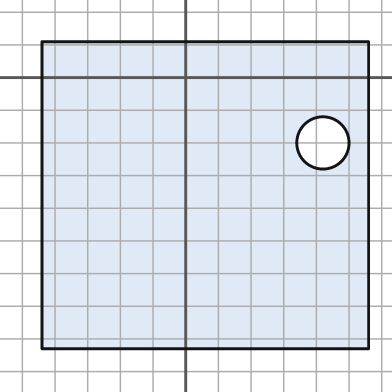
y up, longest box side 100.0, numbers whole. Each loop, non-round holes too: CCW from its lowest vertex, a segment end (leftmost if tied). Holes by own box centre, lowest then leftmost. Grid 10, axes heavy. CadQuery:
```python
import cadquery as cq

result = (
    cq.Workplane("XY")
    .moveTo(-44.0, -83.0)
    .lineTo(56.0, -83.0)
    .lineTo(56.0, 11.0)
    .lineTo(-44.0, 11.0)
    .close()
    .moveTo(42.0, -20.0)
    .circle(8.0)
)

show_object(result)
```